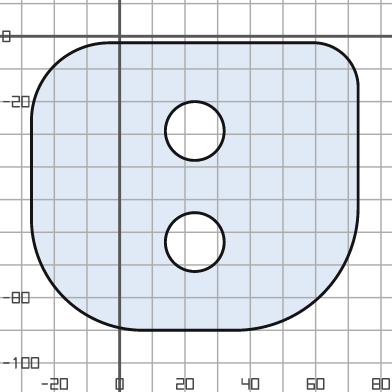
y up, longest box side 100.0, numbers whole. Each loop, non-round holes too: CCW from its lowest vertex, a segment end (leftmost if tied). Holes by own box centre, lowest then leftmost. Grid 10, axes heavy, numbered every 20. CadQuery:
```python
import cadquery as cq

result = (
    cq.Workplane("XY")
    .moveTo(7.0, -90.0)
    .lineTo(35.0, -90.0)
    .threePointArc((62.0, -79.0), (73.0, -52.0))
    .lineTo(73.0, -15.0)
    .threePointArc((69.0, -6.0), (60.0, -2.0))
    .lineTo(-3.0, -2.0)
    .threePointArc((-20.0, -9.0), (-27.0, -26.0))
    .lineTo(-27.0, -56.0)
    .threePointArc((-17.0, -80.0), (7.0, -90.0))
    .close()
    .moveTo(23.0, -63.0)
    .circle(9.0)
    .moveTo(23.0, -29.0)
    .circle(9.0)
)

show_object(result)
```